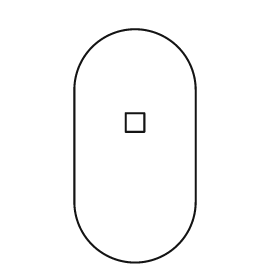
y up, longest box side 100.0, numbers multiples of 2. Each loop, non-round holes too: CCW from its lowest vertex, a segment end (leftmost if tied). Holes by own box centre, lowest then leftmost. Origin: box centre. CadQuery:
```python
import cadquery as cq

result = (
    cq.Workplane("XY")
    .moveTo(-26.0, -24.0)
    .threePointArc((0.0, -50.0), (26.0, -24.0))
    .lineTo(26.0, 24.0)
    .threePointArc((0.0, 50.0), (-26.0, 24.0))
    .close()
    .moveTo(-4.0, 6.0)
    .lineTo(4.0, 6.0)
    .lineTo(4.0, 14.0)
    .lineTo(-4.0, 14.0)
    .close()
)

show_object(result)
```